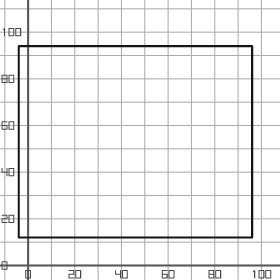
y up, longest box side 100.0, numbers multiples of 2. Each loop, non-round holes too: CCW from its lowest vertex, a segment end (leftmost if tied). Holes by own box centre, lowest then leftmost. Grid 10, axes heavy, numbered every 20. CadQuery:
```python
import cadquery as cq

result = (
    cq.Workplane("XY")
    .moveTo(-4.0, 12.0)
    .lineTo(96.0, 12.0)
    .lineTo(96.0, 94.0)
    .lineTo(-4.0, 94.0)
    .close()
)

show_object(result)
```